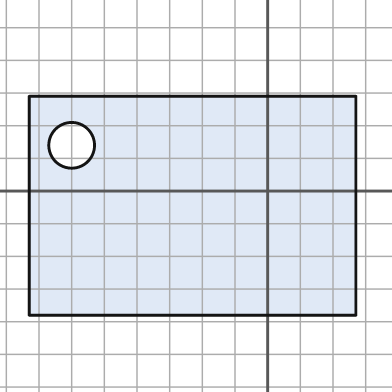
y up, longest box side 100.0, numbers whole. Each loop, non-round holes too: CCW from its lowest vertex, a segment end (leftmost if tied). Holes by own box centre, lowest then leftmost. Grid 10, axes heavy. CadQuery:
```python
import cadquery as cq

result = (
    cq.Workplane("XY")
    .moveTo(-73.0, -38.0)
    .lineTo(27.0, -38.0)
    .lineTo(27.0, 29.0)
    .lineTo(-73.0, 29.0)
    .close()
    .moveTo(-60.0, 14.0)
    .circle(7.0)
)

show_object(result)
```